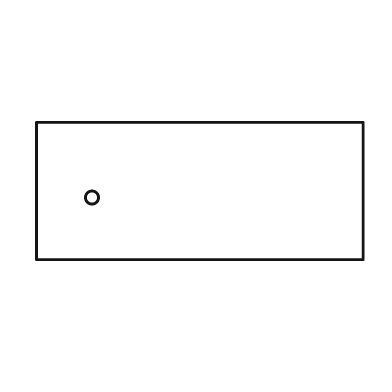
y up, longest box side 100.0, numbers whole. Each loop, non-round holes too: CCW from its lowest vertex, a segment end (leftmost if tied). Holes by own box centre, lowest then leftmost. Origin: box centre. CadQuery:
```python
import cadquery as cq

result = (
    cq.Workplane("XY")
    .moveTo(-50.0, -21.0)
    .lineTo(50.0, -21.0)
    .lineTo(50.0, 21.0)
    .lineTo(-50.0, 21.0)
    .close()
    .moveTo(-33.0, -2.0)
    .circle(2.0)
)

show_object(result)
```